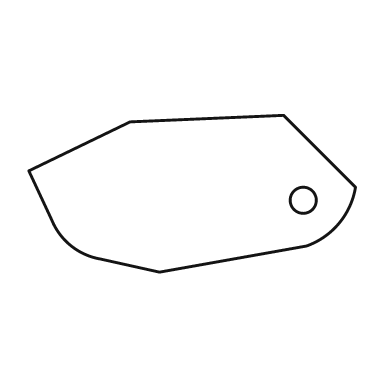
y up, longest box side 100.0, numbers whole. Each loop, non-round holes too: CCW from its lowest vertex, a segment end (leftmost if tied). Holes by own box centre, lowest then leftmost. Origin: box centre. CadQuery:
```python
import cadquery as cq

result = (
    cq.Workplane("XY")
    .moveTo(-10.0, -24.0)
    .lineTo(35.0, -16.0)
    .threePointArc((45.0, -9.0), (50.0, 2.0))
    .lineTo(28.0, 24.0)
    .lineTo(-19.0, 22.0)
    .lineTo(-50.0, 7.0)
    .lineTo(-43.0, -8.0)
    .threePointArc((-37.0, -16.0), (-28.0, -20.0))
    .close()
    .moveTo(34.0, -2.0)
    .circle(4.0)
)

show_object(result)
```